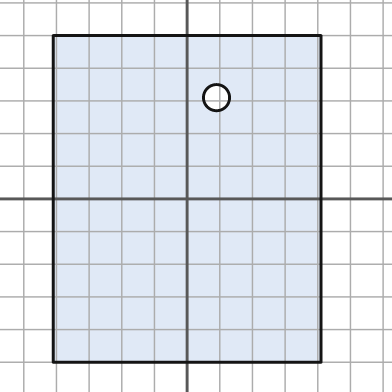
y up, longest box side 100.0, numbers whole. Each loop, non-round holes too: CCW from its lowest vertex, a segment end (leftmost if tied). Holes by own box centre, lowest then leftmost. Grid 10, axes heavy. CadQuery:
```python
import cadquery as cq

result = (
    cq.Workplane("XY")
    .moveTo(-41.0, -50.0)
    .lineTo(41.0, -50.0)
    .lineTo(41.0, 50.0)
    .lineTo(-41.0, 50.0)
    .close()
    .moveTo(9.0, 31.0)
    .circle(4.0)
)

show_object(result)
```